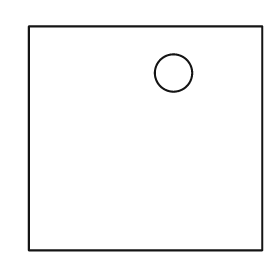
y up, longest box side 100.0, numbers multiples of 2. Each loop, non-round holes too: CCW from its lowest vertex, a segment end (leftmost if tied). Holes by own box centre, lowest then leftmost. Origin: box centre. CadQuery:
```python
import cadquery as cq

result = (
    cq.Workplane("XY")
    .moveTo(-50.0, -48.0)
    .lineTo(50.0, -48.0)
    .lineTo(50.0, 48.0)
    .lineTo(-50.0, 48.0)
    .close()
    .moveTo(12.0, 28.0)
    .circle(8.0)
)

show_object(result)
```